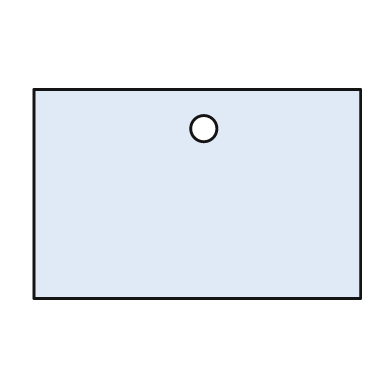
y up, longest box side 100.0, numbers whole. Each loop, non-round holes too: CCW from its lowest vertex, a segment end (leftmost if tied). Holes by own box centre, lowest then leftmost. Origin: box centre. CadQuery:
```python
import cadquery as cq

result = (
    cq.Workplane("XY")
    .moveTo(-50.0, -32.0)
    .lineTo(50.0, -32.0)
    .lineTo(50.0, 32.0)
    .lineTo(-50.0, 32.0)
    .close()
    .moveTo(2.0, 20.0)
    .circle(4.0)
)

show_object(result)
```